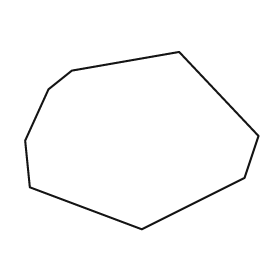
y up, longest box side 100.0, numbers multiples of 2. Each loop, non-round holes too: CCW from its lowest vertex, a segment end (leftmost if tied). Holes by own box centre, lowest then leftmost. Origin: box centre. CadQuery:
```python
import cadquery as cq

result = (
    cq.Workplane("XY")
    .moveTo(0.0, -38.0)
    .lineTo(44.0, -16.0)
    .lineTo(50.0, 2.0)
    .lineTo(16.0, 38.0)
    .lineTo(-30.0, 30.0)
    .lineTo(-40.0, 22.0)
    .lineTo(-50.0, 0.0)
    .lineTo(-48.0, -20.0)
    .close()
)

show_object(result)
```